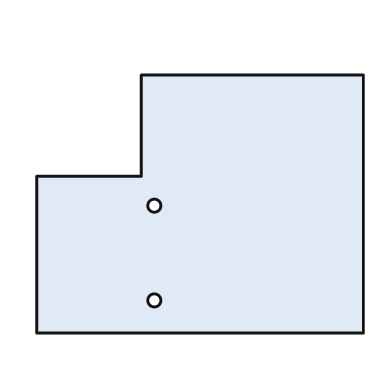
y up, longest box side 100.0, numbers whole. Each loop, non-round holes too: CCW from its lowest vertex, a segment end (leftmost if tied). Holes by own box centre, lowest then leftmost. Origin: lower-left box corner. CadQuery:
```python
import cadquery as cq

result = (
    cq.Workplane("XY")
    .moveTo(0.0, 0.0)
    .lineTo(100.0, 0.0)
    .lineTo(100.0, 79.0)
    .lineTo(32.0, 79.0)
    .lineTo(32.0, 48.0)
    .lineTo(0.0, 48.0)
    .close()
    .moveTo(36.0, 10.0)
    .circle(2.0)
    .moveTo(36.0, 39.0)
    .circle(2.0)
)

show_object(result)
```